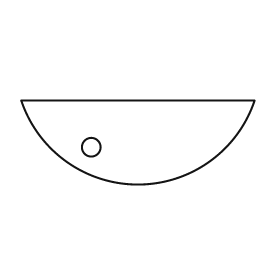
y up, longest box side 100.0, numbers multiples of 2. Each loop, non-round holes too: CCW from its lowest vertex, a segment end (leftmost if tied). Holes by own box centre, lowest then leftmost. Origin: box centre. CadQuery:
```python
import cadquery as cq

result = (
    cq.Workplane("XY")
    .moveTo(-50.0, 18.0)
    .threePointArc((0.0, -18.0), (50.0, 18.0))
    .close()
    .moveTo(-20.0, -2.0)
    .circle(4.0)
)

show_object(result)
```